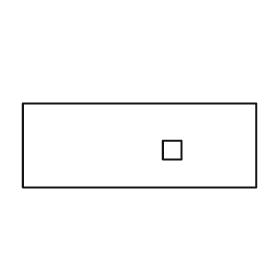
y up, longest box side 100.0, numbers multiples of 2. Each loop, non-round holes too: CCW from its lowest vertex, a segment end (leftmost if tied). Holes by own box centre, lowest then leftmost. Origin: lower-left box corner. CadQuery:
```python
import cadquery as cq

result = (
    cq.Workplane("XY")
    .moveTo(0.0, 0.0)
    .lineTo(100.0, 0.0)
    .lineTo(100.0, 36.0)
    .lineTo(0.0, 36.0)
    .close()
    .moveTo(60.0, 12.0)
    .lineTo(68.0, 12.0)
    .lineTo(68.0, 20.0)
    .lineTo(60.0, 20.0)
    .close()
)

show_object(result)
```